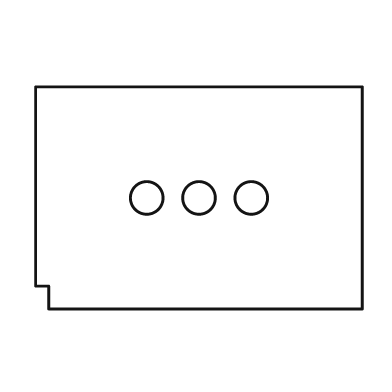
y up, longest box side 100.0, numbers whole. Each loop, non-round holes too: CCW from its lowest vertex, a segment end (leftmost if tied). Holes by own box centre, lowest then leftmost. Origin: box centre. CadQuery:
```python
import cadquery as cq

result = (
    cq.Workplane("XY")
    .moveTo(-46.0, -34.0)
    .lineTo(50.0, -34.0)
    .lineTo(50.0, 34.0)
    .lineTo(-50.0, 34.0)
    .lineTo(-50.0, -27.0)
    .lineTo(-46.0, -27.0)
    .close()
    .moveTo(-16.0, 0.0)
    .circle(5.0)
    .moveTo(0.0, 0.0)
    .circle(5.0)
    .moveTo(16.0, 0.0)
    .circle(5.0)
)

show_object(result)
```